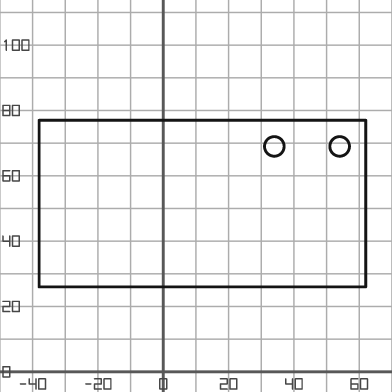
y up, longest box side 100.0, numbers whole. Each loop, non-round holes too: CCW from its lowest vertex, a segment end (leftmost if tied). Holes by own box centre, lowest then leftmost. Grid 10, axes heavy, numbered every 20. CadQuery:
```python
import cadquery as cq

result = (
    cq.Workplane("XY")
    .moveTo(-38.0, 26.0)
    .lineTo(62.0, 26.0)
    .lineTo(62.0, 77.0)
    .lineTo(-38.0, 77.0)
    .close()
    .moveTo(34.0, 69.0)
    .circle(3.0)
    .moveTo(54.0, 69.0)
    .circle(3.0)
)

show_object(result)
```